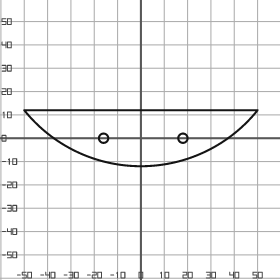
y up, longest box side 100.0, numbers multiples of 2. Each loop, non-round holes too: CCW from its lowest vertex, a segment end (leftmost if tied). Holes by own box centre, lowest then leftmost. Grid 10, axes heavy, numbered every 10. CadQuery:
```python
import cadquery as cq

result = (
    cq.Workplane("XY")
    .moveTo(-50.0, 12.0)
    .threePointArc((0.0, -12.0), (50.0, 12.0))
    .close()
    .moveTo(-16.0, 0.0)
    .circle(2.0)
    .moveTo(18.0, 0.0)
    .circle(2.0)
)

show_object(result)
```